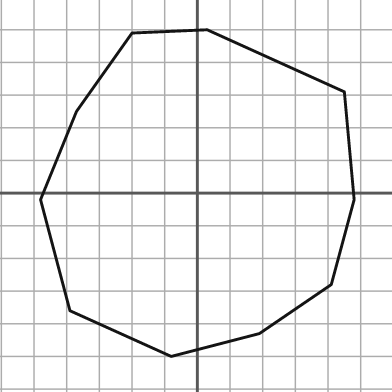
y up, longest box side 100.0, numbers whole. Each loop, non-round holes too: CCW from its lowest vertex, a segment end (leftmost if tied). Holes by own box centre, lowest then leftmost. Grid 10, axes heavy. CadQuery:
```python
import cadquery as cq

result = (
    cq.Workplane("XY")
    .moveTo(-8.0, -50.0)
    .lineTo(19.0, -43.0)
    .lineTo(41.0, -28.0)
    .lineTo(48.0, -2.0)
    .lineTo(45.0, 31.0)
    .lineTo(3.0, 50.0)
    .lineTo(-20.0, 49.0)
    .lineTo(-37.0, 25.0)
    .lineTo(-48.0, -2.0)
    .lineTo(-39.0, -36.0)
    .close()
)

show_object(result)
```